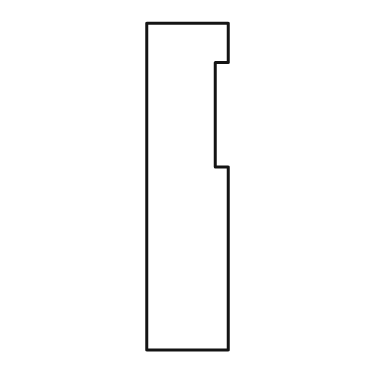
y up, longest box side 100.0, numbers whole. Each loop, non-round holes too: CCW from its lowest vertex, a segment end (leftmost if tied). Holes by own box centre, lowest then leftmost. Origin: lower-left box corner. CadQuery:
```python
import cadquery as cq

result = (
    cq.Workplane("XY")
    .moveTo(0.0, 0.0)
    .lineTo(25.0, 0.0)
    .lineTo(25.0, 56.0)
    .lineTo(21.0, 56.0)
    .lineTo(21.0, 88.0)
    .lineTo(25.0, 88.0)
    .lineTo(25.0, 100.0)
    .lineTo(0.0, 100.0)
    .close()
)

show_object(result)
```